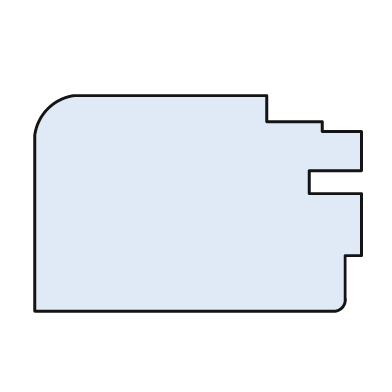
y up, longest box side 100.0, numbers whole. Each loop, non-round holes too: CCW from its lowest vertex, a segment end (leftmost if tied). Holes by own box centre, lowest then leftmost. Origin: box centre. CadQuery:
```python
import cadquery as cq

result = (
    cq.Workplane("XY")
    .moveTo(-50.0, -33.0)
    .lineTo(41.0, -33.0)
    .threePointArc((44.0, -32.0), (45.0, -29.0))
    .lineTo(45.0, -16.0)
    .lineTo(50.0, -16.0)
    .lineTo(50.0, 3.0)
    .lineTo(34.0, 3.0)
    .lineTo(34.0, 10.0)
    .lineTo(50.0, 10.0)
    .lineTo(50.0, 22.0)
    .lineTo(38.0, 22.0)
    .lineTo(38.0, 25.0)
    .lineTo(21.0, 25.0)
    .lineTo(21.0, 33.0)
    .lineTo(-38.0, 33.0)
    .threePointArc((-46.0, 29.0), (-50.0, 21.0))
    .close()
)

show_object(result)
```